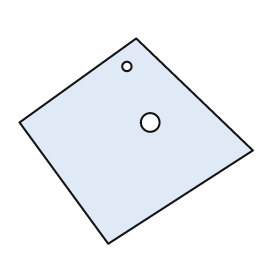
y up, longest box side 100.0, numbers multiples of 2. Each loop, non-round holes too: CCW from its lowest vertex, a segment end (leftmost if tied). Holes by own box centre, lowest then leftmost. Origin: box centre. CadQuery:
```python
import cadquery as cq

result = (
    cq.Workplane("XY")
    .moveTo(-12.0, -44.0)
    .lineTo(50.0, -4.0)
    .lineTo(0.0, 44.0)
    .lineTo(-50.0, 8.0)
    .close()
    .moveTo(6.0, 8.0)
    .circle(4.0)
    .moveTo(-4.0, 32.0)
    .circle(2.0)
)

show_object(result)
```